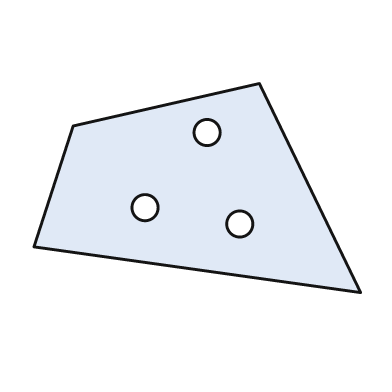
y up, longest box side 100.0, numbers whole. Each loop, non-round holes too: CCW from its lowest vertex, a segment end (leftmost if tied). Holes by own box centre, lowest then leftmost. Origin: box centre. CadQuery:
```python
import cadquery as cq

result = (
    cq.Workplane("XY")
    .moveTo(50.0, -32.0)
    .lineTo(19.0, 32.0)
    .lineTo(-38.0, 19.0)
    .lineTo(-50.0, -18.0)
    .close()
    .moveTo(13.0, -11.0)
    .circle(4.0)
    .moveTo(-16.0, -6.0)
    .circle(4.0)
    .moveTo(3.0, 17.0)
    .circle(4.0)
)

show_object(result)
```